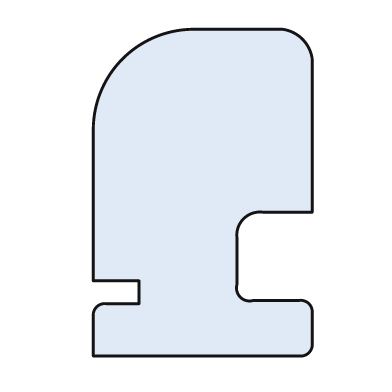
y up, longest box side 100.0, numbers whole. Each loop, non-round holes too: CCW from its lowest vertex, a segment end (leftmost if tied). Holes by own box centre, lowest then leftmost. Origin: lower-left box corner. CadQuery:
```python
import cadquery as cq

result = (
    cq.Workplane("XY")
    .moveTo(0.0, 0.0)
    .lineTo(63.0, 0.0)
    .threePointArc((66.0, 1.0), (67.0, 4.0))
    .lineTo(67.0, 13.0)
    .threePointArc((66.0, 16.0), (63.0, 17.0))
    .lineTo(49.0, 17.0)
    .threePointArc((45.0, 18.0), (44.0, 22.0))
    .lineTo(44.0, 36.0)
    .threePointArc((46.0, 42.0), (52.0, 44.0))
    .lineTo(67.0, 44.0)
    .lineTo(67.0, 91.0)
    .threePointArc((64.0, 97.0), (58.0, 100.0))
    .lineTo(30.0, 100.0)
    .threePointArc((9.0, 91.0), (0.0, 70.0))
    .lineTo(0.0, 23.0)
    .lineTo(14.0, 23.0)
    .lineTo(14.0, 16.0)
    .lineTo(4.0, 16.0)
    .threePointArc((1.0, 15.0), (0.0, 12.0))
    .close()
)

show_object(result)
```